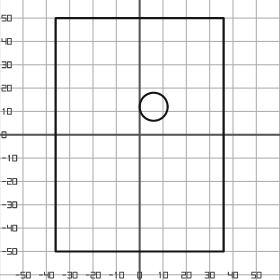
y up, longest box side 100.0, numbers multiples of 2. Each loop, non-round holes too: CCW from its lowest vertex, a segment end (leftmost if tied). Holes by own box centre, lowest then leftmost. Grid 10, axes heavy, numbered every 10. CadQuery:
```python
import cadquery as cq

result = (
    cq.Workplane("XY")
    .moveTo(-36.0, -50.0)
    .lineTo(36.0, -50.0)
    .lineTo(36.0, 50.0)
    .lineTo(-36.0, 50.0)
    .close()
    .moveTo(6.0, 12.0)
    .circle(6.0)
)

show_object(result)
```